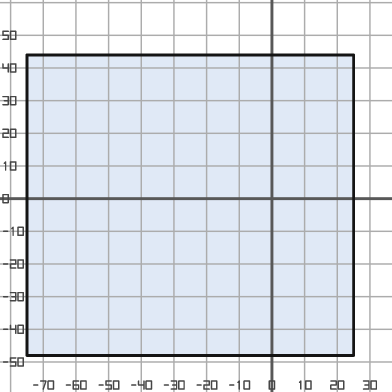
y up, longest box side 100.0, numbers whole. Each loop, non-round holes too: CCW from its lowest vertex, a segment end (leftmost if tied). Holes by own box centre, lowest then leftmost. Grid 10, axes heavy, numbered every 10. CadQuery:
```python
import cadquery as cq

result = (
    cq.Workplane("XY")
    .moveTo(-75.0, -48.0)
    .lineTo(25.0, -48.0)
    .lineTo(25.0, 44.0)
    .lineTo(-75.0, 44.0)
    .close()
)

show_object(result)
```